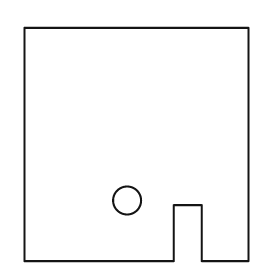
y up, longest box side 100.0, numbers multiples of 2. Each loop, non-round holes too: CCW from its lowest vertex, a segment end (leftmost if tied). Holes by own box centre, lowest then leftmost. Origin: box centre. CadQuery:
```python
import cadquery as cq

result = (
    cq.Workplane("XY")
    .moveTo(-48.0, -50.0)
    .lineTo(16.0, -50.0)
    .lineTo(16.0, -26.0)
    .lineTo(28.0, -26.0)
    .lineTo(28.0, -50.0)
    .lineTo(48.0, -50.0)
    .lineTo(48.0, 50.0)
    .lineTo(-48.0, 50.0)
    .close()
    .moveTo(-4.0, -24.0)
    .circle(6.0)
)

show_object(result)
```